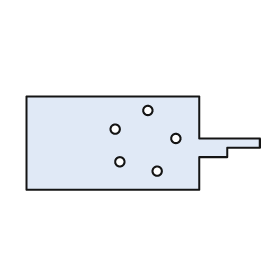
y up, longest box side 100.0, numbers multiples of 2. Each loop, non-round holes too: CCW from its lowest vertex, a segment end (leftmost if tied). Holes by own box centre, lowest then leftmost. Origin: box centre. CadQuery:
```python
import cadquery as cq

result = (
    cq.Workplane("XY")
    .moveTo(-50.0, -20.0)
    .lineTo(24.0, -20.0)
    .lineTo(24.0, -6.0)
    .lineTo(36.0, -6.0)
    .lineTo(36.0, -2.0)
    .lineTo(50.0, -2.0)
    .lineTo(50.0, 2.0)
    .lineTo(24.0, 2.0)
    .lineTo(24.0, 20.0)
    .lineTo(-50.0, 20.0)
    .close()
    .moveTo(6.0, -12.0)
    .circle(2.0)
    .moveTo(-10.0, -8.0)
    .circle(2.0)
    .moveTo(14.0, 2.0)
    .circle(2.0)
    .moveTo(-12.0, 6.0)
    .circle(2.0)
    .moveTo(2.0, 14.0)
    .circle(2.0)
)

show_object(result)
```